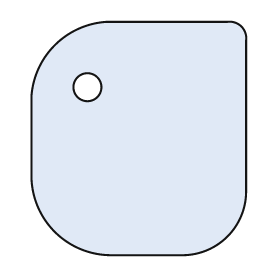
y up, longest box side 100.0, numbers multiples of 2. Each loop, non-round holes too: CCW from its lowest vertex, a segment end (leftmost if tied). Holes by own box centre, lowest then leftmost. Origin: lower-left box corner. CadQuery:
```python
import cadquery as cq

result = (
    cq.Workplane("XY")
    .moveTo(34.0, 0.0)
    .lineTo(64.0, 0.0)
    .threePointArc((84.0, 8.0), (92.0, 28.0))
    .lineTo(92.0, 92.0)
    .threePointArc((90.0, 98.0), (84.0, 100.0))
    .lineTo(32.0, 100.0)
    .threePointArc((10.0, 90.0), (0.0, 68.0))
    .lineTo(0.0, 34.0)
    .threePointArc((10.0, 10.0), (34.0, 0.0))
    .close()
    .moveTo(24.0, 72.0)
    .circle(6.0)
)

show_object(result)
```